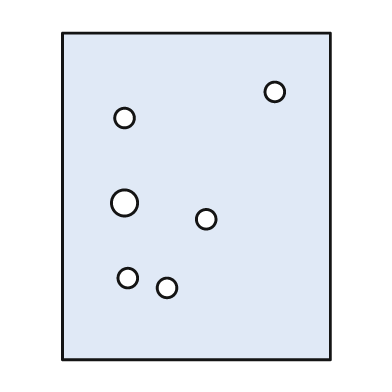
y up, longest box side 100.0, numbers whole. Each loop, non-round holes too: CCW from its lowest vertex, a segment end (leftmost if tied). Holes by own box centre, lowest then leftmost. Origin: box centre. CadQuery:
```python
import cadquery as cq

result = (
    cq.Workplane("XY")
    .moveTo(-41.0, -50.0)
    .lineTo(41.0, -50.0)
    .lineTo(41.0, 50.0)
    .lineTo(-41.0, 50.0)
    .close()
    .moveTo(-9.0, -28.0)
    .circle(3.0)
    .moveTo(-21.0, -25.0)
    .circle(3.0)
    .moveTo(3.0, -7.0)
    .circle(3.0)
    .moveTo(-22.0, -2.0)
    .circle(4.0)
    .moveTo(-22.0, 24.0)
    .circle(3.0)
    .moveTo(24.0, 32.0)
    .circle(3.0)
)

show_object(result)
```